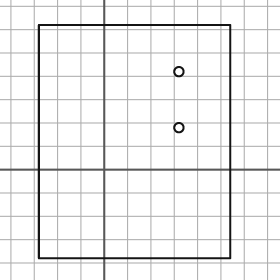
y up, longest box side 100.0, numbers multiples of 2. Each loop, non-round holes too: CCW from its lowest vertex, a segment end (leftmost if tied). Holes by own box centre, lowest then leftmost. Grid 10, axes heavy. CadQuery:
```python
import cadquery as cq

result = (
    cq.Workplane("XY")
    .moveTo(-28.0, -38.0)
    .lineTo(54.0, -38.0)
    .lineTo(54.0, 62.0)
    .lineTo(-28.0, 62.0)
    .close()
    .moveTo(32.0, 18.0)
    .circle(2.0)
    .moveTo(32.0, 42.0)
    .circle(2.0)
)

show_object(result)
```